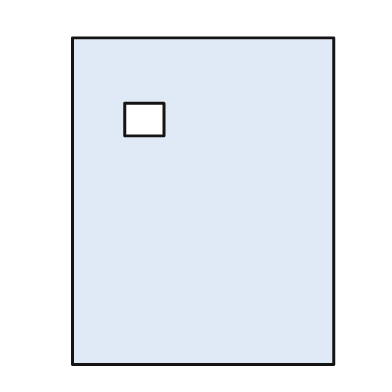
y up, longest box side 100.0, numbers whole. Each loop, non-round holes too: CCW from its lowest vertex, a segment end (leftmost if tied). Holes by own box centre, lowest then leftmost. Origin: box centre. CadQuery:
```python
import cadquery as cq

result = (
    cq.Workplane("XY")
    .moveTo(-40.0, -50.0)
    .lineTo(40.0, -50.0)
    .lineTo(40.0, 50.0)
    .lineTo(-40.0, 50.0)
    .close()
    .moveTo(-24.0, 20.0)
    .lineTo(-12.0, 20.0)
    .lineTo(-12.0, 30.0)
    .lineTo(-24.0, 30.0)
    .close()
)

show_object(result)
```